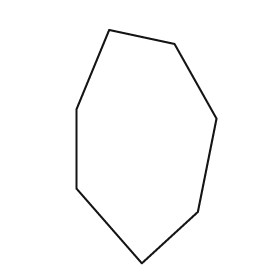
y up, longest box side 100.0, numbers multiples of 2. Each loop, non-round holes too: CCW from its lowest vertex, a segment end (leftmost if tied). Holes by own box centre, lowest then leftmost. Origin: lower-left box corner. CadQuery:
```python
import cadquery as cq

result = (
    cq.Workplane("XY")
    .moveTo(28.0, 0.0)
    .lineTo(52.0, 22.0)
    .lineTo(60.0, 62.0)
    .lineTo(42.0, 94.0)
    .lineTo(14.0, 100.0)
    .lineTo(0.0, 66.0)
    .lineTo(0.0, 32.0)
    .close()
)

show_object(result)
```